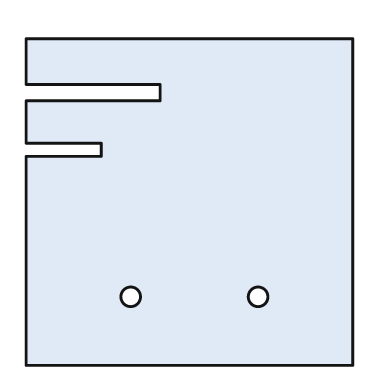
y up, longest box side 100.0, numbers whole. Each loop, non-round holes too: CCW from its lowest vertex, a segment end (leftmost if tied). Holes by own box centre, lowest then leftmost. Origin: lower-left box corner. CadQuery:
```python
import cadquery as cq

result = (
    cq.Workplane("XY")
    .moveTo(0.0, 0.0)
    .lineTo(100.0, 0.0)
    .lineTo(100.0, 100.0)
    .lineTo(0.0, 100.0)
    .lineTo(0.0, 86.0)
    .lineTo(41.0, 86.0)
    .lineTo(41.0, 81.0)
    .lineTo(0.0, 81.0)
    .lineTo(0.0, 68.0)
    .lineTo(23.0, 68.0)
    .lineTo(23.0, 64.0)
    .lineTo(0.0, 64.0)
    .close()
    .moveTo(32.0, 21.0)
    .circle(3.0)
    .moveTo(71.0, 21.0)
    .circle(3.0)
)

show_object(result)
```